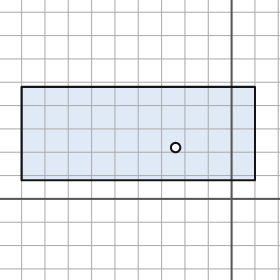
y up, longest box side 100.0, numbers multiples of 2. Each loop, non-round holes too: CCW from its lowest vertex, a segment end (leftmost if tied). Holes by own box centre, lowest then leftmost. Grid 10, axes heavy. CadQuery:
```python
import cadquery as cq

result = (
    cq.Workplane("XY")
    .moveTo(-90.0, 8.0)
    .lineTo(10.0, 8.0)
    .lineTo(10.0, 48.0)
    .lineTo(-90.0, 48.0)
    .close()
    .moveTo(-24.0, 22.0)
    .circle(2.0)
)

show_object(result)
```